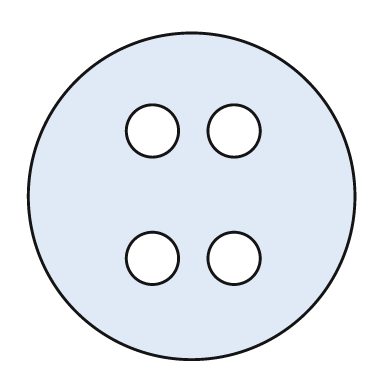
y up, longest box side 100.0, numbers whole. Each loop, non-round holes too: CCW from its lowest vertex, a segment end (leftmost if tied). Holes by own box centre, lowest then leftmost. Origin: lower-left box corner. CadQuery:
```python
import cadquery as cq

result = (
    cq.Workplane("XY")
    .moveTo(50.0, 50.0)
    .circle(50.0)
    .moveTo(38.0, 31.0)
    .circle(8.0)
    .moveTo(63.0, 31.0)
    .circle(8.0)
    .moveTo(38.0, 70.0)
    .circle(8.0)
    .moveTo(63.0, 70.0)
    .circle(8.0)
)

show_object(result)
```